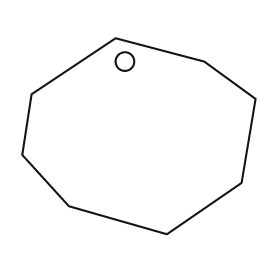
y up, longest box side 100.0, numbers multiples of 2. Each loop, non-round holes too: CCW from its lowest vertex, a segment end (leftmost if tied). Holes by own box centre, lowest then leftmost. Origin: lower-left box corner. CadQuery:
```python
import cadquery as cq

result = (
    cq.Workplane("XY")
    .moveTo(62.0, 0.0)
    .lineTo(94.0, 22.0)
    .lineTo(100.0, 58.0)
    .lineTo(78.0, 74.0)
    .lineTo(40.0, 84.0)
    .lineTo(4.0, 60.0)
    .lineTo(0.0, 34.0)
    .lineTo(20.0, 12.0)
    .close()
    .moveTo(44.0, 74.0)
    .circle(4.0)
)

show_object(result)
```